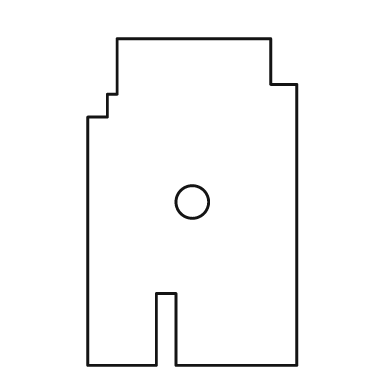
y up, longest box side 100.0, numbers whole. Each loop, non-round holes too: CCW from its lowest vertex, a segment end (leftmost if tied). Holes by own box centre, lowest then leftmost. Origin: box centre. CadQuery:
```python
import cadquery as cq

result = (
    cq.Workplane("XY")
    .moveTo(-32.0, -50.0)
    .lineTo(-11.0, -50.0)
    .lineTo(-11.0, -28.0)
    .lineTo(-5.0, -28.0)
    .lineTo(-5.0, -50.0)
    .lineTo(32.0, -50.0)
    .lineTo(32.0, 36.0)
    .lineTo(24.0, 36.0)
    .lineTo(24.0, 50.0)
    .lineTo(-23.0, 50.0)
    .lineTo(-23.0, 33.0)
    .lineTo(-26.0, 33.0)
    .lineTo(-26.0, 26.0)
    .lineTo(-32.0, 26.0)
    .close()
    .moveTo(0.0, 0.0)
    .circle(5.0)
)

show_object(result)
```